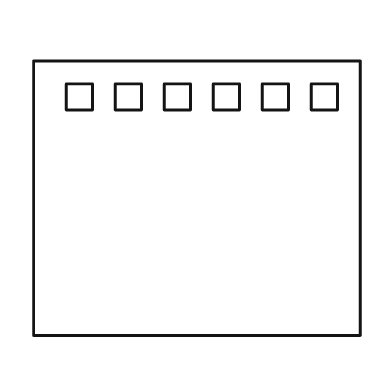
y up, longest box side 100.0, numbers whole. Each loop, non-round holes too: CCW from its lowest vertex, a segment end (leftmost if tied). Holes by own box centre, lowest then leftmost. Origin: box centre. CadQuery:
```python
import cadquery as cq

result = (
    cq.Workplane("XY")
    .moveTo(-50.0, -42.0)
    .lineTo(50.0, -42.0)
    .lineTo(50.0, 42.0)
    .lineTo(-50.0, 42.0)
    .close()
    .moveTo(-40.0, 27.0)
    .lineTo(-32.0, 27.0)
    .lineTo(-32.0, 35.0)
    .lineTo(-40.0, 35.0)
    .close()
    .moveTo(-25.0, 27.0)
    .lineTo(-17.0, 27.0)
    .lineTo(-17.0, 35.0)
    .lineTo(-25.0, 35.0)
    .close()
    .moveTo(-10.0, 27.0)
    .lineTo(-2.0, 27.0)
    .lineTo(-2.0, 35.0)
    .lineTo(-10.0, 35.0)
    .close()
    .moveTo(5.0, 27.0)
    .lineTo(13.0, 27.0)
    .lineTo(13.0, 35.0)
    .lineTo(5.0, 35.0)
    .close()
    .moveTo(20.0, 27.0)
    .lineTo(28.0, 27.0)
    .lineTo(28.0, 35.0)
    .lineTo(20.0, 35.0)
    .close()
    .moveTo(35.0, 27.0)
    .lineTo(43.0, 27.0)
    .lineTo(43.0, 35.0)
    .lineTo(35.0, 35.0)
    .close()
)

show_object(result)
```